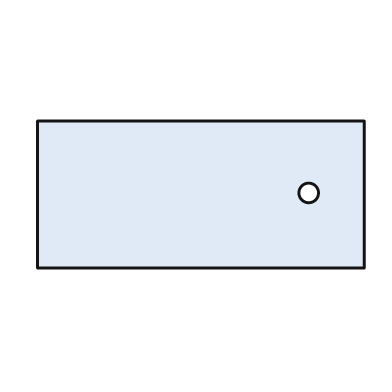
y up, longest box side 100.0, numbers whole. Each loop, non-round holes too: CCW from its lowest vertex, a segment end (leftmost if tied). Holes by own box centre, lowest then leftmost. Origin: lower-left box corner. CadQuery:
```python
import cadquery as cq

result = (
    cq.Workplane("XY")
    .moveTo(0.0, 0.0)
    .lineTo(100.0, 0.0)
    .lineTo(100.0, 45.0)
    .lineTo(0.0, 45.0)
    .close()
    .moveTo(83.0, 23.0)
    .circle(3.0)
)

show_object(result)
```